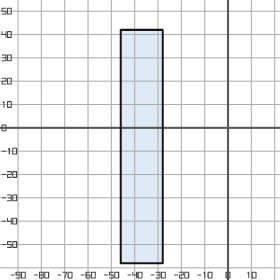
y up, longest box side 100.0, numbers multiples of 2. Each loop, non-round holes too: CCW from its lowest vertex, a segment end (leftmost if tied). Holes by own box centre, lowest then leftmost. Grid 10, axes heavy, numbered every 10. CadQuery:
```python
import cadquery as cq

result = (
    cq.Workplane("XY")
    .moveTo(-46.0, -58.0)
    .lineTo(-28.0, -58.0)
    .lineTo(-28.0, 42.0)
    .lineTo(-46.0, 42.0)
    .close()
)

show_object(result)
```